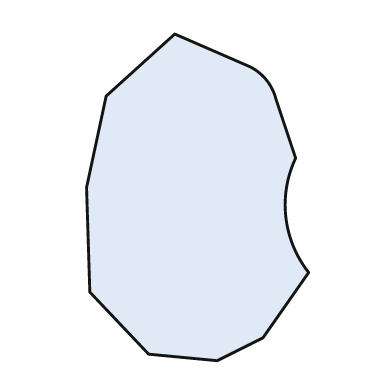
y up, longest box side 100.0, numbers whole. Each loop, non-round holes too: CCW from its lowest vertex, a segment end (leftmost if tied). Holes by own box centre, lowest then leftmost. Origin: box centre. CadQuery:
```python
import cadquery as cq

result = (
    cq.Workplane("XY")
    .moveTo(6.0, -50.0)
    .lineTo(20.0, -43.0)
    .lineTo(34.0, -23.0)
    .threePointArc((27.0, -6.0), (30.0, 12.0))
    .lineTo(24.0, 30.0)
    .threePointArc((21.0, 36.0), (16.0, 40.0))
    .lineTo(-7.0, 50.0)
    .lineTo(-28.0, 31.0)
    .lineTo(-34.0, 3.0)
    .lineTo(-33.0, -29.0)
    .lineTo(-15.0, -48.0)
    .close()
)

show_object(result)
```